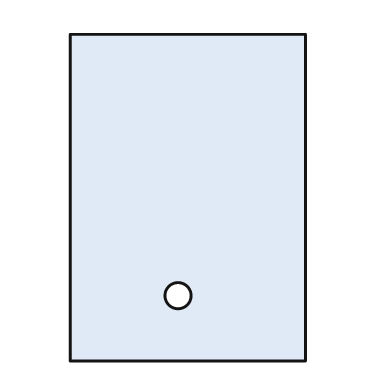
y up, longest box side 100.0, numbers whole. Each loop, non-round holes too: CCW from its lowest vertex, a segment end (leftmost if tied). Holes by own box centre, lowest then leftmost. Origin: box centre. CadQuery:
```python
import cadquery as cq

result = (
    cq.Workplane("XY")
    .moveTo(-36.0, -50.0)
    .lineTo(36.0, -50.0)
    .lineTo(36.0, 50.0)
    .lineTo(-36.0, 50.0)
    .close()
    .moveTo(-3.0, -30.0)
    .circle(4.0)
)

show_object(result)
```